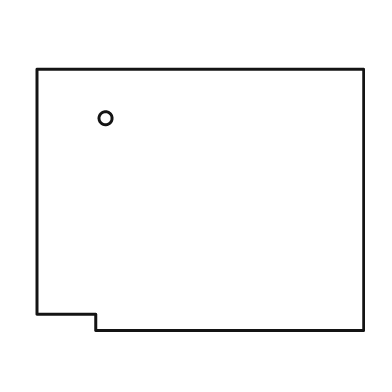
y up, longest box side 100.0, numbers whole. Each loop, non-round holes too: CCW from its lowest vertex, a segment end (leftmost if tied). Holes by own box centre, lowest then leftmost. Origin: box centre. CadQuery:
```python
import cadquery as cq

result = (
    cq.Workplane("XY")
    .moveTo(-32.0, -40.0)
    .lineTo(50.0, -40.0)
    .lineTo(50.0, 40.0)
    .lineTo(-50.0, 40.0)
    .lineTo(-50.0, -35.0)
    .lineTo(-32.0, -35.0)
    .close()
    .moveTo(-29.0, 25.0)
    .circle(2.0)
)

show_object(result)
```